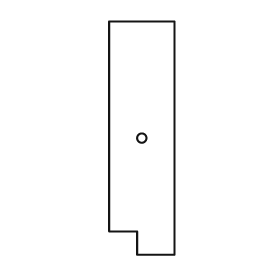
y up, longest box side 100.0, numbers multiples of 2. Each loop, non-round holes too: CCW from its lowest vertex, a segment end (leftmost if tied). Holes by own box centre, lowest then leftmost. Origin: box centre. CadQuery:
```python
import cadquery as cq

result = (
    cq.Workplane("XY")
    .moveTo(-2.0, -50.0)
    .lineTo(14.0, -50.0)
    .lineTo(14.0, 50.0)
    .lineTo(-14.0, 50.0)
    .lineTo(-14.0, -40.0)
    .lineTo(-2.0, -40.0)
    .close()
    .moveTo(0.0, 0.0)
    .circle(2.0)
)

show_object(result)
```